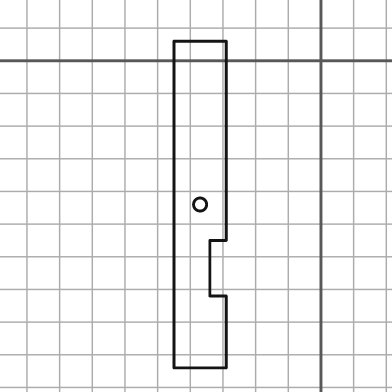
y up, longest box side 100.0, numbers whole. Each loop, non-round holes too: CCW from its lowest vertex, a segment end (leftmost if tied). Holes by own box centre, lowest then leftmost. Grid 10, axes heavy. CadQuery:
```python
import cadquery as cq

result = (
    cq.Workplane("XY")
    .moveTo(-45.0, -94.0)
    .lineTo(-29.0, -94.0)
    .lineTo(-29.0, -72.0)
    .lineTo(-34.0, -72.0)
    .lineTo(-34.0, -55.0)
    .lineTo(-29.0, -55.0)
    .lineTo(-29.0, 6.0)
    .lineTo(-45.0, 6.0)
    .close()
    .moveTo(-37.0, -44.0)
    .circle(2.0)
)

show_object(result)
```